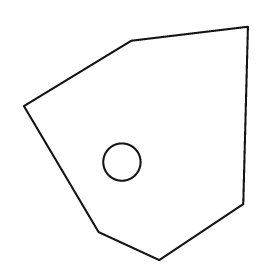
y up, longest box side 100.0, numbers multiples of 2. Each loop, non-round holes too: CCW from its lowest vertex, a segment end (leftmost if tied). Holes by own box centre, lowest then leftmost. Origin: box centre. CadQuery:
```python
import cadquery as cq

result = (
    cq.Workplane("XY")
    .moveTo(10.0, -50.0)
    .lineTo(46.0, -26.0)
    .lineTo(48.0, 50.0)
    .lineTo(-2.0, 44.0)
    .lineTo(-48.0, 16.0)
    .lineTo(-16.0, -38.0)
    .close()
    .moveTo(-6.0, -8.0)
    .circle(8.0)
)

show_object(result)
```